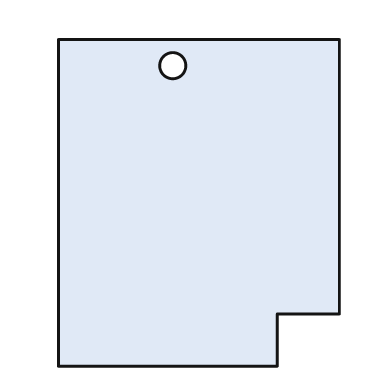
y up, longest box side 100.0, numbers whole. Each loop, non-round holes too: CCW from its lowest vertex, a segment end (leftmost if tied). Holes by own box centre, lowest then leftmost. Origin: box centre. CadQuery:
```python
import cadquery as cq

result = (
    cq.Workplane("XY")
    .moveTo(-43.0, -50.0)
    .lineTo(24.0, -50.0)
    .lineTo(24.0, -34.0)
    .lineTo(43.0, -34.0)
    .lineTo(43.0, 50.0)
    .lineTo(-43.0, 50.0)
    .close()
    .moveTo(-8.0, 42.0)
    .circle(4.0)
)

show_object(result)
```